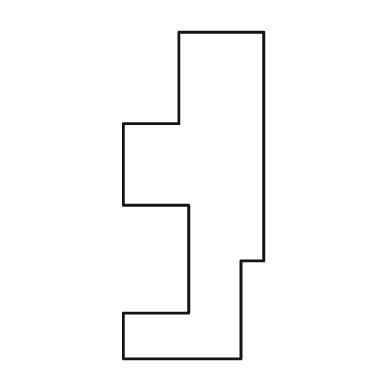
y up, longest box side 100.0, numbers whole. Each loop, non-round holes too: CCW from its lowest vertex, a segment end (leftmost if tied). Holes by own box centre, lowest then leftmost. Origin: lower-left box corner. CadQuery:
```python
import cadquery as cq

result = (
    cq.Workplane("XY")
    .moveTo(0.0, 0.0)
    .lineTo(36.0, 0.0)
    .lineTo(36.0, 30.0)
    .lineTo(43.0, 30.0)
    .lineTo(43.0, 100.0)
    .lineTo(17.0, 100.0)
    .lineTo(17.0, 72.0)
    .lineTo(0.0, 72.0)
    .lineTo(0.0, 47.0)
    .lineTo(20.0, 47.0)
    .lineTo(20.0, 14.0)
    .lineTo(0.0, 14.0)
    .close()
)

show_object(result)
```